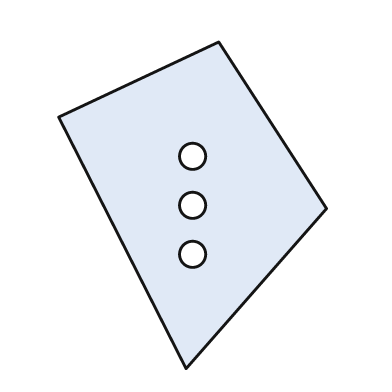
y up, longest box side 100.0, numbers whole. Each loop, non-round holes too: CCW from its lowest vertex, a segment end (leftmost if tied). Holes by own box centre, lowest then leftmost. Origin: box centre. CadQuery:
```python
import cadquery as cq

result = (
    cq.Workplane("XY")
    .moveTo(-2.0, -50.0)
    .lineTo(41.0, -1.0)
    .lineTo(8.0, 50.0)
    .lineTo(-41.0, 27.0)
    .close()
    .moveTo(0.0, -15.0)
    .circle(4.0)
    .moveTo(0.0, 0.0)
    .circle(4.0)
    .moveTo(0.0, 15.0)
    .circle(4.0)
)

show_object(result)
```